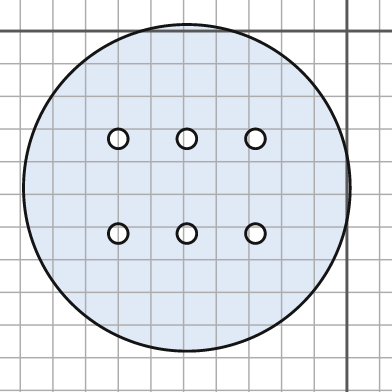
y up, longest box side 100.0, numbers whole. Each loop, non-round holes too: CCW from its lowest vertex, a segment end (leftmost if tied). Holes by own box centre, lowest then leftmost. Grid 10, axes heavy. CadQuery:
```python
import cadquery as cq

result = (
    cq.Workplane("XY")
    .moveTo(-49.0, -48.0)
    .circle(50.0)
    .moveTo(-70.0, -62.0)
    .circle(3.0)
    .moveTo(-49.0, -62.0)
    .circle(3.0)
    .moveTo(-28.0, -62.0)
    .circle(3.0)
    .moveTo(-70.0, -33.0)
    .circle(3.0)
    .moveTo(-49.0, -33.0)
    .circle(3.0)
    .moveTo(-28.0, -33.0)
    .circle(3.0)
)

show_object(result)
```